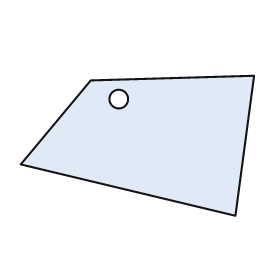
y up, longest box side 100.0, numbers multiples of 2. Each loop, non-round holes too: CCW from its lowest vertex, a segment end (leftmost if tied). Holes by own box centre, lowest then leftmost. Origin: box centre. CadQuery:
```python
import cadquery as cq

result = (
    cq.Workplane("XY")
    .moveTo(42.0, -30.0)
    .lineTo(50.0, 30.0)
    .lineTo(-20.0, 28.0)
    .lineTo(-50.0, -8.0)
    .close()
    .moveTo(-8.0, 20.0)
    .circle(4.0)
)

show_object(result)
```